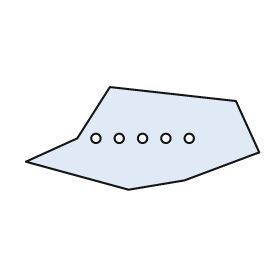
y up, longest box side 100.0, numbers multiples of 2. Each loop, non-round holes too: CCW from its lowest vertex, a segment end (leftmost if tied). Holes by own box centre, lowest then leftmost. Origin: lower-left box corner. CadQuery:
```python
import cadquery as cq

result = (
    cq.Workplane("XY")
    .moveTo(44.0, 0.0)
    .lineTo(68.0, 4.0)
    .lineTo(100.0, 16.0)
    .lineTo(90.0, 38.0)
    .lineTo(36.0, 44.0)
    .lineTo(22.0, 22.0)
    .lineTo(0.0, 12.0)
    .close()
    .moveTo(30.0, 22.0)
    .circle(2.0)
    .moveTo(40.0, 22.0)
    .circle(2.0)
    .moveTo(50.0, 22.0)
    .circle(2.0)
    .moveTo(60.0, 22.0)
    .circle(2.0)
    .moveTo(70.0, 22.0)
    .circle(2.0)
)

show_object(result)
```